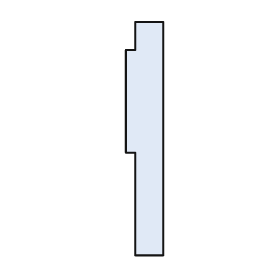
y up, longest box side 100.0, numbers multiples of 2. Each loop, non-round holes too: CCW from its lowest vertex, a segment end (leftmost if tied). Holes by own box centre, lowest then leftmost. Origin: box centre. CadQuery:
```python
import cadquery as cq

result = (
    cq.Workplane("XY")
    .moveTo(-4.0, -50.0)
    .lineTo(8.0, -50.0)
    .lineTo(8.0, 50.0)
    .lineTo(-4.0, 50.0)
    .lineTo(-4.0, 38.0)
    .lineTo(-8.0, 38.0)
    .lineTo(-8.0, -6.0)
    .lineTo(-4.0, -6.0)
    .close()
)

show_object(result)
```